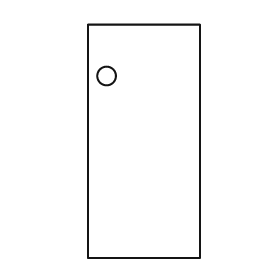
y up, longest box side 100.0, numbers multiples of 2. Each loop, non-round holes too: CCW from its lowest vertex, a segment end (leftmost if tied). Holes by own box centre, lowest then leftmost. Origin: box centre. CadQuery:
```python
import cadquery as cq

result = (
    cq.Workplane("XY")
    .moveTo(-24.0, -50.0)
    .lineTo(24.0, -50.0)
    .lineTo(24.0, 50.0)
    .lineTo(-24.0, 50.0)
    .close()
    .moveTo(-16.0, 28.0)
    .circle(4.0)
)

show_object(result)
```